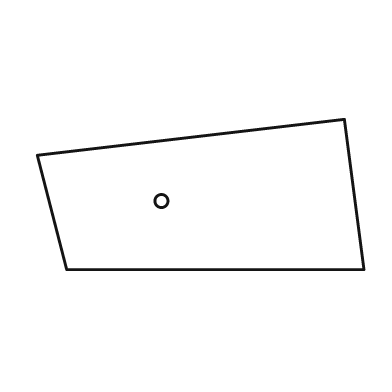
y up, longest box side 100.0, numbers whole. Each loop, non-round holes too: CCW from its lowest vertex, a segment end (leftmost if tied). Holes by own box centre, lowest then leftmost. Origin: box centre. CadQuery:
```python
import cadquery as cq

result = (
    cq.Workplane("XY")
    .moveTo(-41.0, -23.0)
    .lineTo(50.0, -23.0)
    .lineTo(44.0, 23.0)
    .lineTo(-50.0, 12.0)
    .close()
    .moveTo(-12.0, -2.0)
    .circle(2.0)
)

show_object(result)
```